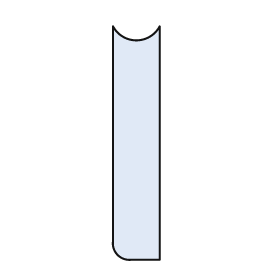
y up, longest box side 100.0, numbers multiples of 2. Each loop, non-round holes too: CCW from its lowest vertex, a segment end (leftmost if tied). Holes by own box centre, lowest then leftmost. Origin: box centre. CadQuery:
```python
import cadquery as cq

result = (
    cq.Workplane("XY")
    .moveTo(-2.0, -50.0)
    .lineTo(10.0, -50.0)
    .lineTo(10.0, 50.0)
    .threePointArc((0.0, 44.0), (-10.0, 50.0))
    .lineTo(-10.0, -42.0)
    .threePointArc((-8.0, -48.0), (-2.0, -50.0))
    .close()
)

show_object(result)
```